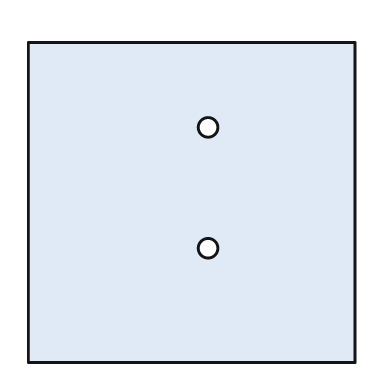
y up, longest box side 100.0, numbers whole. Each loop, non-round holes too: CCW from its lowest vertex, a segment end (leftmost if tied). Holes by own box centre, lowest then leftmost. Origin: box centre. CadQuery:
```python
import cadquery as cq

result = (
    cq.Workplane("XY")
    .moveTo(-50.0, -49.0)
    .lineTo(50.0, -49.0)
    .lineTo(50.0, 49.0)
    .lineTo(-50.0, 49.0)
    .close()
    .moveTo(5.0, -14.0)
    .circle(3.0)
    .moveTo(5.0, 23.0)
    .circle(3.0)
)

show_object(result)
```